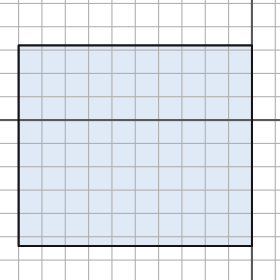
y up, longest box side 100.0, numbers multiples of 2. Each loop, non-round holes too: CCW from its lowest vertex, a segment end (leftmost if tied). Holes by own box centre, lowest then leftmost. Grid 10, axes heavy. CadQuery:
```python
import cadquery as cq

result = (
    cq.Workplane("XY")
    .moveTo(-100.0, -54.0)
    .lineTo(0.0, -54.0)
    .lineTo(0.0, 32.0)
    .lineTo(-100.0, 32.0)
    .close()
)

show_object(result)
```